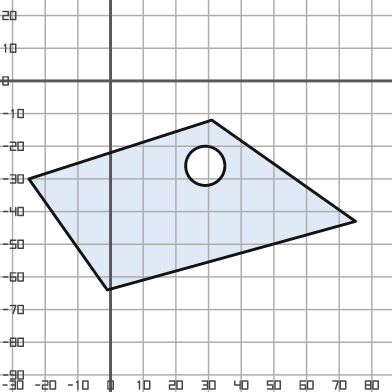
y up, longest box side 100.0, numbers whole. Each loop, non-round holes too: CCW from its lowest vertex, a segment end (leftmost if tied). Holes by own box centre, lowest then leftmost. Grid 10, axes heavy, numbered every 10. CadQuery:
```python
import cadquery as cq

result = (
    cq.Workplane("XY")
    .moveTo(-1.0, -64.0)
    .lineTo(75.0, -43.0)
    .lineTo(31.0, -12.0)
    .lineTo(-25.0, -30.0)
    .close()
    .moveTo(29.0, -26.0)
    .circle(6.0)
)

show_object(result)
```